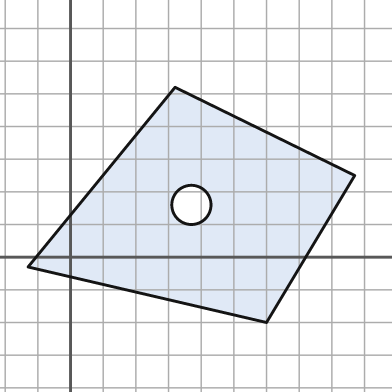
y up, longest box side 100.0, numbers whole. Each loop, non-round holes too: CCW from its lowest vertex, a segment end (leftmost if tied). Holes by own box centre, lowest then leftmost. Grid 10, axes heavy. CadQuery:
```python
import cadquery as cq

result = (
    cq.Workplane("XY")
    .moveTo(60.0, -20.0)
    .lineTo(87.0, 25.0)
    .lineTo(32.0, 52.0)
    .lineTo(-13.0, -3.0)
    .close()
    .moveTo(37.0, 16.0)
    .circle(6.0)
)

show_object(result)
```